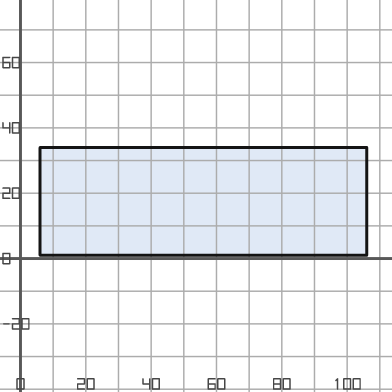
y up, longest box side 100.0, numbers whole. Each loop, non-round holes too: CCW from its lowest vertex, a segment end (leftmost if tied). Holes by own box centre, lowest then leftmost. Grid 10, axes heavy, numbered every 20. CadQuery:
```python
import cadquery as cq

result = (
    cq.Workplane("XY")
    .moveTo(6.0, 1.0)
    .lineTo(106.0, 1.0)
    .lineTo(106.0, 34.0)
    .lineTo(6.0, 34.0)
    .close()
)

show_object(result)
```